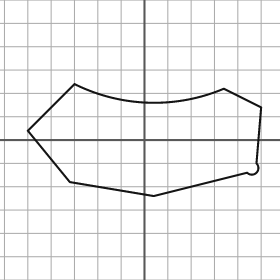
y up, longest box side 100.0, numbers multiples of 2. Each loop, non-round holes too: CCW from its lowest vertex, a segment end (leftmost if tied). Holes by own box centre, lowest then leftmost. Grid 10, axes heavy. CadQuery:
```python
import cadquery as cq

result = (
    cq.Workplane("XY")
    .moveTo(4.0, -24.0)
    .lineTo(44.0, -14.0)
    .threePointArc((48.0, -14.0), (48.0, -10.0))
    .lineTo(50.0, 14.0)
    .lineTo(34.0, 22.0)
    .threePointArc((2.0, 16.0), (-30.0, 24.0))
    .lineTo(-50.0, 4.0)
    .lineTo(-32.0, -18.0)
    .close()
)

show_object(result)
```